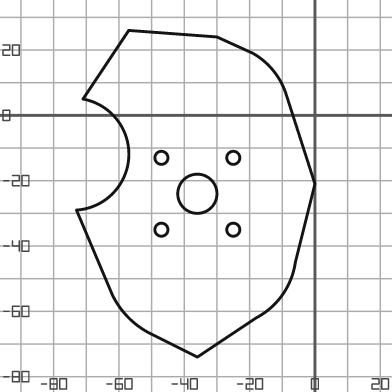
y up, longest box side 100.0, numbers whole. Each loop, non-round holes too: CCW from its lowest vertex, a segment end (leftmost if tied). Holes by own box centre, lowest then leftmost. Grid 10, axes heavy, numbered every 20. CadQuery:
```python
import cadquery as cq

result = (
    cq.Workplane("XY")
    .moveTo(-36.0, -74.0)
    .lineTo(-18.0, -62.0)
    .threePointArc((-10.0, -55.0), (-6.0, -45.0))
    .lineTo(0.0, -21.0)
    .lineTo(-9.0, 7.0)
    .threePointArc((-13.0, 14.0), (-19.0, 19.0))
    .lineTo(-30.0, 24.0)
    .lineTo(-57.0, 26.0)
    .lineTo(-71.0, 5.0)
    .threePointArc((-57.0, -13.0), (-73.0, -29.0))
    .lineTo(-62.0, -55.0)
    .threePointArc((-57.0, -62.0), (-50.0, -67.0))
    .close()
    .moveTo(-47.0, -35.0)
    .circle(2.0)
    .moveTo(-25.0, -35.0)
    .circle(2.0)
    .moveTo(-36.0, -24.0)
    .circle(6.0)
    .moveTo(-47.0, -13.0)
    .circle(2.0)
    .moveTo(-25.0, -13.0)
    .circle(2.0)
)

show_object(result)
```